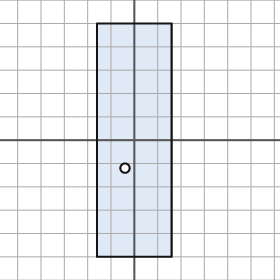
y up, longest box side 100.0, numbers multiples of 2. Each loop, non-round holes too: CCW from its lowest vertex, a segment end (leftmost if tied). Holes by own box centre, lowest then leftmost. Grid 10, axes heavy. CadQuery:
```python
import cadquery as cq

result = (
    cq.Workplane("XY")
    .moveTo(-16.0, -50.0)
    .lineTo(16.0, -50.0)
    .lineTo(16.0, 50.0)
    .lineTo(-16.0, 50.0)
    .close()
    .moveTo(-4.0, -12.0)
    .circle(2.0)
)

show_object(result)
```